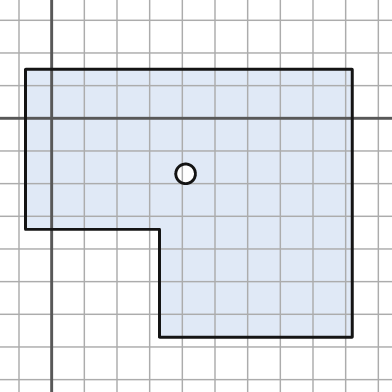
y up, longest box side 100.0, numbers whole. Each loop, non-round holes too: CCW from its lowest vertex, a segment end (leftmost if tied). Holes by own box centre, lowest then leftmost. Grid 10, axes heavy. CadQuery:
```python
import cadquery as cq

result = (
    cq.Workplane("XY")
    .moveTo(33.0, -67.0)
    .lineTo(92.0, -67.0)
    .lineTo(92.0, 15.0)
    .lineTo(-8.0, 15.0)
    .lineTo(-8.0, -34.0)
    .lineTo(33.0, -34.0)
    .close()
    .moveTo(41.0, -17.0)
    .circle(3.0)
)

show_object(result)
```